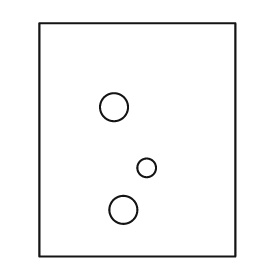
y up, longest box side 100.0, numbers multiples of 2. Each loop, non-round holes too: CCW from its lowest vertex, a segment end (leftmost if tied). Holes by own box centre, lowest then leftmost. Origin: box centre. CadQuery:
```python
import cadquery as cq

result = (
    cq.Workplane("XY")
    .moveTo(-42.0, -50.0)
    .lineTo(42.0, -50.0)
    .lineTo(42.0, 50.0)
    .lineTo(-42.0, 50.0)
    .close()
    .moveTo(-6.0, -30.0)
    .circle(6.0)
    .moveTo(4.0, -12.0)
    .circle(4.0)
    .moveTo(-10.0, 14.0)
    .circle(6.0)
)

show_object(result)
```